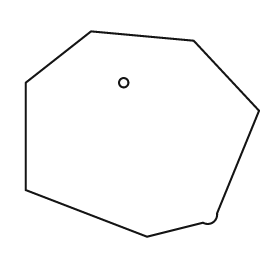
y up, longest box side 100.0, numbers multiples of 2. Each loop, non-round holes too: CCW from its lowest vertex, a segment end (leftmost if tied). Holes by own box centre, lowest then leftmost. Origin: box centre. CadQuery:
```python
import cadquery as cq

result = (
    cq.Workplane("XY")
    .moveTo(2.0, -44.0)
    .lineTo(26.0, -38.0)
    .threePointArc((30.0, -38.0), (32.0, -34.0))
    .lineTo(50.0, 10.0)
    .lineTo(22.0, 40.0)
    .lineTo(-22.0, 44.0)
    .lineTo(-50.0, 22.0)
    .lineTo(-50.0, -24.0)
    .close()
    .moveTo(-8.0, 22.0)
    .circle(2.0)
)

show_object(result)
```